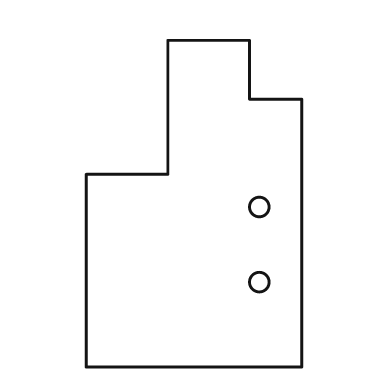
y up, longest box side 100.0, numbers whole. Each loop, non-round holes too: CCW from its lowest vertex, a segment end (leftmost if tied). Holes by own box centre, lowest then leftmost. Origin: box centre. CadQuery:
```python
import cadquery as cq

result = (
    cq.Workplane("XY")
    .moveTo(-33.0, -50.0)
    .lineTo(33.0, -50.0)
    .lineTo(33.0, 32.0)
    .lineTo(17.0, 32.0)
    .lineTo(17.0, 50.0)
    .lineTo(-8.0, 50.0)
    .lineTo(-8.0, 9.0)
    .lineTo(-33.0, 9.0)
    .close()
    .moveTo(20.0, -24.0)
    .circle(3.0)
    .moveTo(20.0, -1.0)
    .circle(3.0)
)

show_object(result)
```